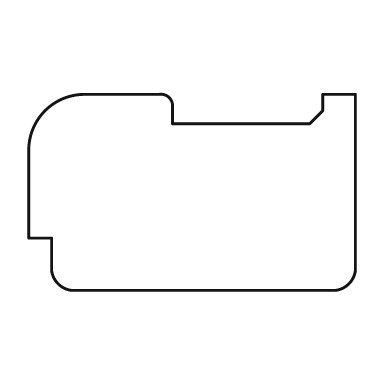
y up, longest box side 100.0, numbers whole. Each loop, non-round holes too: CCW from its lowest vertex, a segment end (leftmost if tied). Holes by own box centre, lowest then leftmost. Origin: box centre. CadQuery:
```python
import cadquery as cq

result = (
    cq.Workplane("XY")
    .moveTo(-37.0, -30.0)
    .lineTo(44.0, -30.0)
    .threePointArc((48.0, -28.0), (50.0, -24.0))
    .lineTo(50.0, 30.0)
    .lineTo(40.0, 30.0)
    .lineTo(40.0, 25.0)
    .lineTo(36.0, 21.0)
    .lineTo(-6.0, 21.0)
    .lineTo(-6.0, 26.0)
    .threePointArc((-7.0, 29.0), (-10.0, 30.0))
    .lineTo(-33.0, 30.0)
    .threePointArc((-45.0, 25.0), (-50.0, 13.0))
    .lineTo(-50.0, -14.0)
    .lineTo(-43.0, -14.0)
    .lineTo(-43.0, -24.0)
    .threePointArc((-41.0, -28.0), (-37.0, -30.0))
    .close()
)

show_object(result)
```